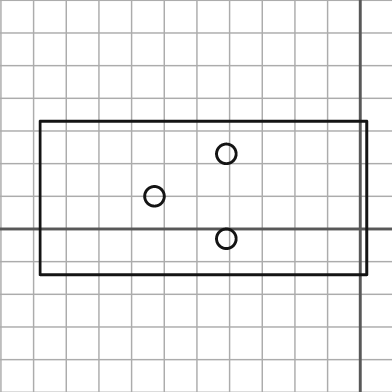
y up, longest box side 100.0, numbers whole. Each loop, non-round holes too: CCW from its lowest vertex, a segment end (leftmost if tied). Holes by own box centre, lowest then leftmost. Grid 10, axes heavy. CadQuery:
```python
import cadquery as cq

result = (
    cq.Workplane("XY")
    .moveTo(-98.0, -14.0)
    .lineTo(2.0, -14.0)
    .lineTo(2.0, 33.0)
    .lineTo(-98.0, 33.0)
    .close()
    .moveTo(-41.0, -3.0)
    .circle(3.0)
    .moveTo(-63.0, 10.0)
    .circle(3.0)
    .moveTo(-41.0, 23.0)
    .circle(3.0)
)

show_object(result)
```